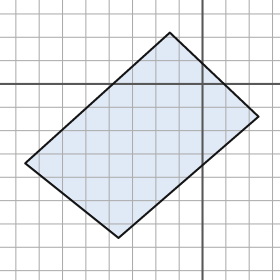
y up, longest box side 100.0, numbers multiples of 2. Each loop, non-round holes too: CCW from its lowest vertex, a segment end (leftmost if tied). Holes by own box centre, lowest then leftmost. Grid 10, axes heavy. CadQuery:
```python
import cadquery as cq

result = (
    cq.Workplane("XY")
    .moveTo(-36.0, -66.0)
    .lineTo(24.0, -14.0)
    .lineTo(-14.0, 22.0)
    .lineTo(-76.0, -34.0)
    .close()
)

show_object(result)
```